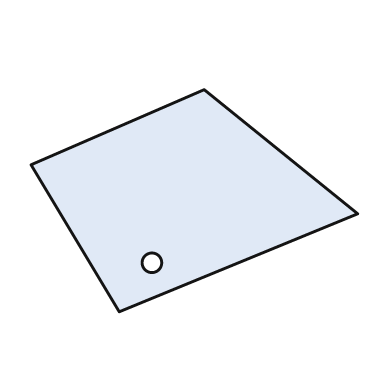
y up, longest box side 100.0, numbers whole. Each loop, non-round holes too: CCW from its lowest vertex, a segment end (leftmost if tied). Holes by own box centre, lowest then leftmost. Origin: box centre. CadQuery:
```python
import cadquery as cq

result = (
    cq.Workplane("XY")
    .moveTo(-23.0, -34.0)
    .lineTo(50.0, -4.0)
    .lineTo(3.0, 34.0)
    .lineTo(-50.0, 11.0)
    .close()
    .moveTo(-13.0, -19.0)
    .circle(3.0)
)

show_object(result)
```